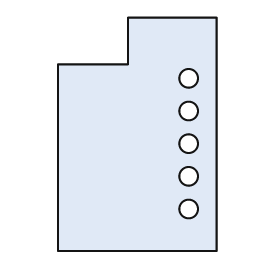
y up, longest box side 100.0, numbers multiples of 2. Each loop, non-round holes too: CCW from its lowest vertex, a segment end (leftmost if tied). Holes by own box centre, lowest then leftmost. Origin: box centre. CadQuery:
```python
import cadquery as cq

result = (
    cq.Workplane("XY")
    .moveTo(-34.0, -50.0)
    .lineTo(34.0, -50.0)
    .lineTo(34.0, 50.0)
    .lineTo(-4.0, 50.0)
    .lineTo(-4.0, 30.0)
    .lineTo(-34.0, 30.0)
    .close()
    .moveTo(22.0, -32.0)
    .circle(4.0)
    .moveTo(22.0, -18.0)
    .circle(4.0)
    .moveTo(22.0, -4.0)
    .circle(4.0)
    .moveTo(22.0, 10.0)
    .circle(4.0)
    .moveTo(22.0, 24.0)
    .circle(4.0)
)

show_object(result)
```